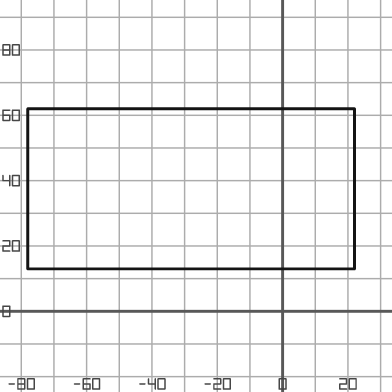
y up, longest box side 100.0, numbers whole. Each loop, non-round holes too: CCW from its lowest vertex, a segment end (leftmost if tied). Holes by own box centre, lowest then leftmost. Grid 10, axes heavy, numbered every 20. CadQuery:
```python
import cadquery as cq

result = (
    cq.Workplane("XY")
    .moveTo(-78.0, 13.0)
    .lineTo(22.0, 13.0)
    .lineTo(22.0, 62.0)
    .lineTo(-78.0, 62.0)
    .close()
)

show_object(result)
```